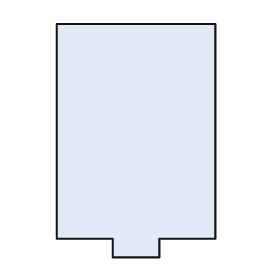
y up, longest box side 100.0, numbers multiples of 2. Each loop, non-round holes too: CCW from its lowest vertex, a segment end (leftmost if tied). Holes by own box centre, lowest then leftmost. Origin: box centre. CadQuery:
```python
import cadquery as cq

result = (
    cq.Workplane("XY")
    .moveTo(-10.0, -50.0)
    .lineTo(10.0, -50.0)
    .lineTo(10.0, -42.0)
    .lineTo(34.0, -42.0)
    .lineTo(34.0, 50.0)
    .lineTo(-34.0, 50.0)
    .lineTo(-34.0, -42.0)
    .lineTo(-10.0, -42.0)
    .close()
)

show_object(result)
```